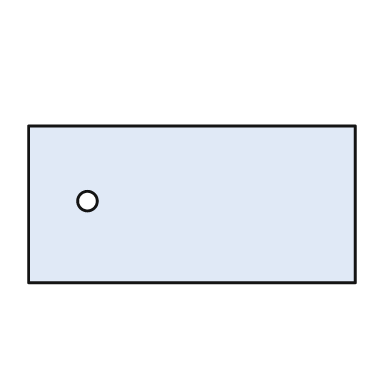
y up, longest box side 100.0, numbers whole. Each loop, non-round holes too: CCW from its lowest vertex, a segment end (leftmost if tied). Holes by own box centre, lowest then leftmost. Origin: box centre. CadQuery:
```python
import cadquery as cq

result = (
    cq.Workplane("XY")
    .moveTo(-50.0, -24.0)
    .lineTo(50.0, -24.0)
    .lineTo(50.0, 24.0)
    .lineTo(-50.0, 24.0)
    .close()
    .moveTo(-32.0, 1.0)
    .circle(3.0)
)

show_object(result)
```